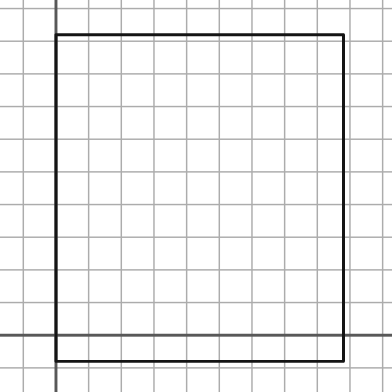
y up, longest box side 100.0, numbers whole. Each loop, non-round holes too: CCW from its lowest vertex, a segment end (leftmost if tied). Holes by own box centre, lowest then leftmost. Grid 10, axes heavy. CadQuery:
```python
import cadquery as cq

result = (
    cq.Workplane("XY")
    .moveTo(0.0, -8.0)
    .lineTo(88.0, -8.0)
    .lineTo(88.0, 92.0)
    .lineTo(0.0, 92.0)
    .close()
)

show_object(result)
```